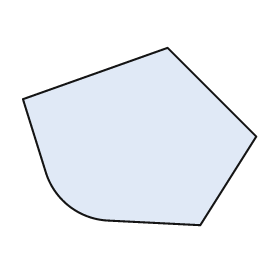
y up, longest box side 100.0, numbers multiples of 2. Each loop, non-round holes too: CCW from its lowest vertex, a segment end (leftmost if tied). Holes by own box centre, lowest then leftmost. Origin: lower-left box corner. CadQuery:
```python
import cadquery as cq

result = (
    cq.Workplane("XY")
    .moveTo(76.0, 0.0)
    .lineTo(100.0, 38.0)
    .lineTo(62.0, 76.0)
    .lineTo(0.0, 54.0)
    .lineTo(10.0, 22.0)
    .threePointArc((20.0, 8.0), (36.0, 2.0))
    .close()
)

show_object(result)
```